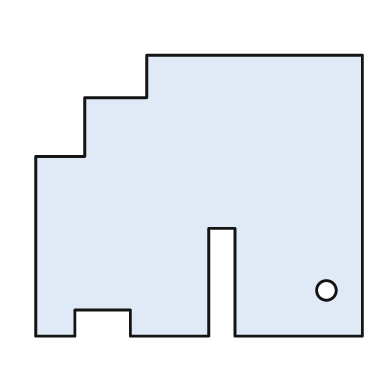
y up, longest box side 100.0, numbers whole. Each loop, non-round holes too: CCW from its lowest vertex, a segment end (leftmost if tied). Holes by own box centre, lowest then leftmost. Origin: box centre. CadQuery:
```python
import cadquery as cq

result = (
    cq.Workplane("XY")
    .moveTo(-50.0, -43.0)
    .lineTo(-38.0, -43.0)
    .lineTo(-38.0, -35.0)
    .lineTo(-21.0, -35.0)
    .lineTo(-21.0, -43.0)
    .lineTo(3.0, -43.0)
    .lineTo(3.0, -10.0)
    .lineTo(11.0, -10.0)
    .lineTo(11.0, -43.0)
    .lineTo(50.0, -43.0)
    .lineTo(50.0, 43.0)
    .lineTo(-16.0, 43.0)
    .lineTo(-16.0, 30.0)
    .lineTo(-35.0, 30.0)
    .lineTo(-35.0, 12.0)
    .lineTo(-50.0, 12.0)
    .close()
    .moveTo(39.0, -29.0)
    .circle(3.0)
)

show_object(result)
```